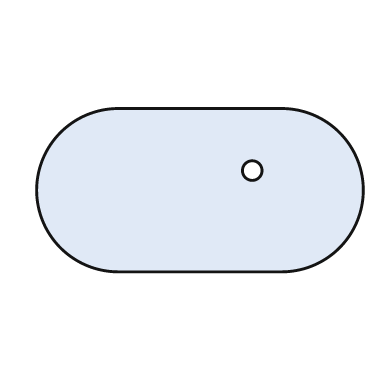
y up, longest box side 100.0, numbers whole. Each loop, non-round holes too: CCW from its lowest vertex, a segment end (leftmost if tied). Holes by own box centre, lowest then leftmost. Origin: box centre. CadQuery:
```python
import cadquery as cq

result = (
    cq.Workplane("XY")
    .moveTo(-25.0, -25.0)
    .lineTo(25.0, -25.0)
    .threePointArc((50.0, 0.0), (25.0, 25.0))
    .lineTo(-25.0, 25.0)
    .threePointArc((-50.0, 0.0), (-25.0, -25.0))
    .close()
    .moveTo(16.0, 6.0)
    .circle(3.0)
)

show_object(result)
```